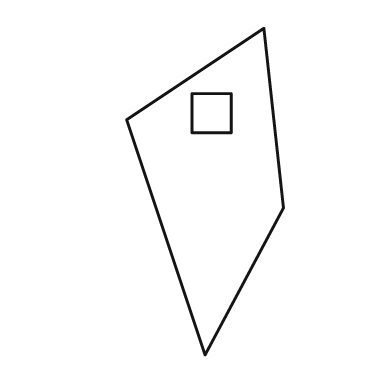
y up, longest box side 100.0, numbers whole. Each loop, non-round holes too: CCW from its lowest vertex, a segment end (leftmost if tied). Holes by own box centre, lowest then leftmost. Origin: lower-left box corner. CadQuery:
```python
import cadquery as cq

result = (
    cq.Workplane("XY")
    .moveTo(24.0, 0.0)
    .lineTo(48.0, 45.0)
    .lineTo(42.0, 100.0)
    .lineTo(0.0, 72.0)
    .close()
    .moveTo(20.0, 68.0)
    .lineTo(32.0, 68.0)
    .lineTo(32.0, 80.0)
    .lineTo(20.0, 80.0)
    .close()
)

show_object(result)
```